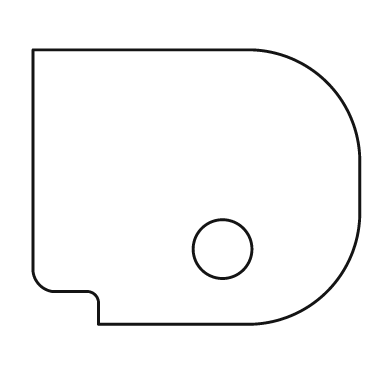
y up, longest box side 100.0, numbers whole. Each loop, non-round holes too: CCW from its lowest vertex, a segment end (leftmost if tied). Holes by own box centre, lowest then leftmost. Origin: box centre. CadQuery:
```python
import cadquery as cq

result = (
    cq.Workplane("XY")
    .moveTo(-30.0, -42.0)
    .lineTo(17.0, -42.0)
    .threePointArc((40.0, -32.0), (50.0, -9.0))
    .lineTo(50.0, 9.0)
    .threePointArc((40.0, 32.0), (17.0, 42.0))
    .lineTo(-50.0, 42.0)
    .lineTo(-50.0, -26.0)
    .threePointArc((-48.0, -30.0), (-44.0, -32.0))
    .lineTo(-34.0, -32.0)
    .threePointArc((-31.0, -33.0), (-30.0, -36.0))
    .close()
    .moveTo(8.0, -19.0)
    .circle(9.0)
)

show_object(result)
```